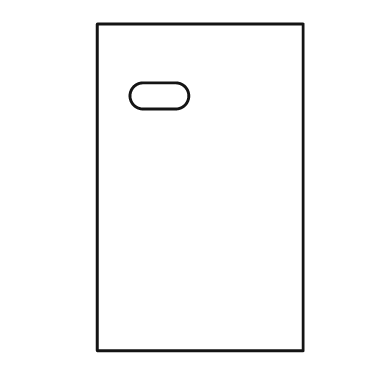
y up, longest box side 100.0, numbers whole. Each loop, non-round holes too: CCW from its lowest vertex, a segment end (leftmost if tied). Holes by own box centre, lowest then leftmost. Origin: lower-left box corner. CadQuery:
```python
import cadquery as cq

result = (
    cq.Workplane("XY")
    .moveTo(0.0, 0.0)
    .lineTo(63.0, 0.0)
    .lineTo(63.0, 100.0)
    .lineTo(0.0, 100.0)
    .close()
    .moveTo(14.0, 74.0)
    .lineTo(24.0, 74.0)
    .threePointArc((28.0, 78.0), (24.0, 82.0))
    .lineTo(14.0, 82.0)
    .threePointArc((10.0, 78.0), (14.0, 74.0))
    .close()
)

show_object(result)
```